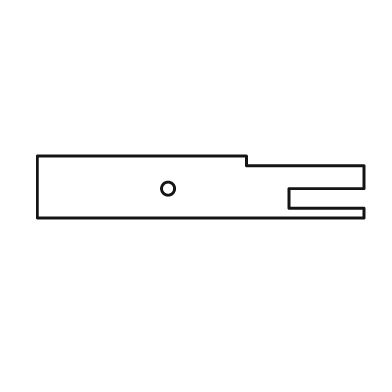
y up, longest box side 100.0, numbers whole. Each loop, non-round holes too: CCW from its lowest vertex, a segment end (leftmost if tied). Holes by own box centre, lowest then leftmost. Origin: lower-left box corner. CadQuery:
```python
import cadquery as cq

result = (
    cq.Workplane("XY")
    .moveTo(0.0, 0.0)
    .lineTo(100.0, 0.0)
    .lineTo(100.0, 3.0)
    .lineTo(77.0, 3.0)
    .lineTo(77.0, 9.0)
    .lineTo(100.0, 9.0)
    .lineTo(100.0, 16.0)
    .lineTo(64.0, 16.0)
    .lineTo(64.0, 19.0)
    .lineTo(0.0, 19.0)
    .close()
    .moveTo(40.0, 9.0)
    .circle(2.0)
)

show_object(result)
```